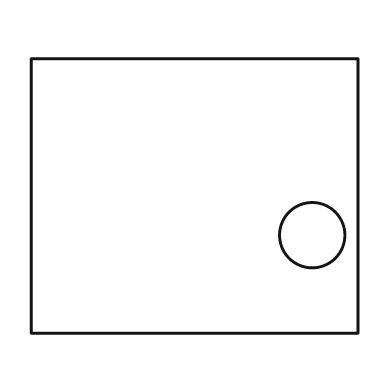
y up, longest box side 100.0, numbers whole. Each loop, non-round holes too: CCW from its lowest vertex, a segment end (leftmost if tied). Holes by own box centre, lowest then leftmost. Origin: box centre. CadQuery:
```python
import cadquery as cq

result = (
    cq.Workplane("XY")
    .moveTo(-50.0, -42.0)
    .lineTo(50.0, -42.0)
    .lineTo(50.0, 42.0)
    .lineTo(-50.0, 42.0)
    .close()
    .moveTo(36.0, -12.0)
    .circle(10.0)
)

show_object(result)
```